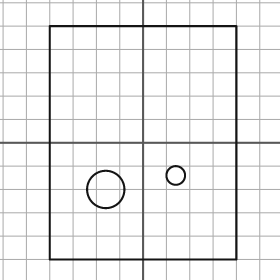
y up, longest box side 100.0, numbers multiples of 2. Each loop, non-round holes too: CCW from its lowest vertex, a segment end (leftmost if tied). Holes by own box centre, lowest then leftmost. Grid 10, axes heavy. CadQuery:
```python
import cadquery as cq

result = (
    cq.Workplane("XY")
    .moveTo(-40.0, -50.0)
    .lineTo(40.0, -50.0)
    .lineTo(40.0, 50.0)
    .lineTo(-40.0, 50.0)
    .close()
    .moveTo(-16.0, -20.0)
    .circle(8.0)
    .moveTo(14.0, -14.0)
    .circle(4.0)
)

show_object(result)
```